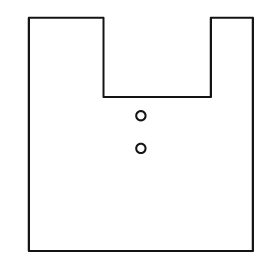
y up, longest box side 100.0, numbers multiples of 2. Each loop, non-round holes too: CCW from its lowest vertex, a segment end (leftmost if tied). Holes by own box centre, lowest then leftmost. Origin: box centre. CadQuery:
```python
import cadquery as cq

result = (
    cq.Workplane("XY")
    .moveTo(-48.0, -50.0)
    .lineTo(48.0, -50.0)
    .lineTo(48.0, 50.0)
    .lineTo(30.0, 50.0)
    .lineTo(30.0, 16.0)
    .lineTo(-16.0, 16.0)
    .lineTo(-16.0, 50.0)
    .lineTo(-48.0, 50.0)
    .close()
    .moveTo(0.0, -6.0)
    .circle(2.0)
    .moveTo(0.0, 8.0)
    .circle(2.0)
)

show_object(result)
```